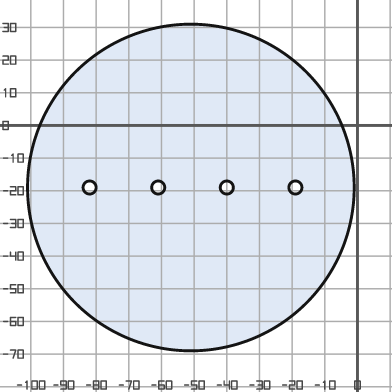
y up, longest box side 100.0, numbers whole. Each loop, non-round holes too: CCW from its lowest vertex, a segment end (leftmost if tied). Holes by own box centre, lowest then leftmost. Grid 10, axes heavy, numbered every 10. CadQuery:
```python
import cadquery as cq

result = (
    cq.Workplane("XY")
    .moveTo(-51.0, -19.0)
    .circle(50.0)
    .moveTo(-82.0, -19.0)
    .circle(2.0)
    .moveTo(-61.0, -19.0)
    .circle(2.0)
    .moveTo(-40.0, -19.0)
    .circle(2.0)
    .moveTo(-19.0, -19.0)
    .circle(2.0)
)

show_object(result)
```